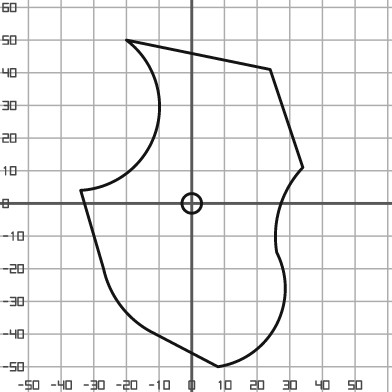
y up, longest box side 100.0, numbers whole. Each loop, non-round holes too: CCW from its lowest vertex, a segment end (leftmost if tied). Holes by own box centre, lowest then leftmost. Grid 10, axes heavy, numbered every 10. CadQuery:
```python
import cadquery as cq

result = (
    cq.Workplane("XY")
    .moveTo(8.0, -50.0)
    .threePointArc((26.0, -37.0), (26.0, -15.0))
    .threePointArc((27.0, -1.0), (34.0, 11.0))
    .lineTo(24.0, 41.0)
    .lineTo(-20.0, 50.0)
    .threePointArc((-11.0, 22.0), (-34.0, 4.0))
    .lineTo(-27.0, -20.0)
    .threePointArc((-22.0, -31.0), (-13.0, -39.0))
    .close()
    .moveTo(0.0, 0.0)
    .circle(3.0)
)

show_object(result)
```